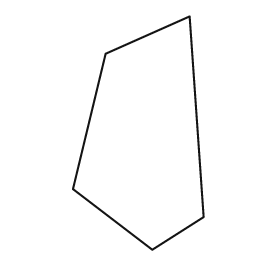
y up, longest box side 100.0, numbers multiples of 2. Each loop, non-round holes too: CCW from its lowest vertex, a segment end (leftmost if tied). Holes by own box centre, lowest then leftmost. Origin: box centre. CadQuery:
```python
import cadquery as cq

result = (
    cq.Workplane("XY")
    .moveTo(6.0, -50.0)
    .lineTo(28.0, -36.0)
    .lineTo(22.0, 50.0)
    .lineTo(-14.0, 34.0)
    .lineTo(-28.0, -24.0)
    .close()
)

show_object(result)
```